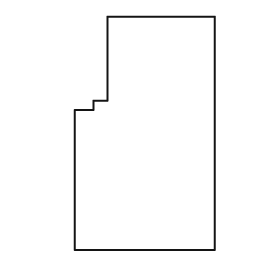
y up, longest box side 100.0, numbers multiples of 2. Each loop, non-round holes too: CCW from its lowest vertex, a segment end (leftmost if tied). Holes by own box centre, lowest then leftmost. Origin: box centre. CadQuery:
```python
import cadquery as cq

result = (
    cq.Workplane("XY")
    .moveTo(-30.0, -50.0)
    .lineTo(30.0, -50.0)
    .lineTo(30.0, 50.0)
    .lineTo(-16.0, 50.0)
    .lineTo(-16.0, 14.0)
    .lineTo(-22.0, 14.0)
    .lineTo(-22.0, 10.0)
    .lineTo(-30.0, 10.0)
    .close()
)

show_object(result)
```